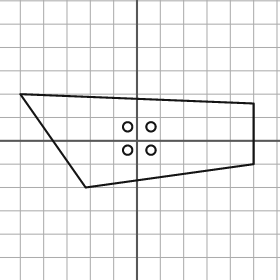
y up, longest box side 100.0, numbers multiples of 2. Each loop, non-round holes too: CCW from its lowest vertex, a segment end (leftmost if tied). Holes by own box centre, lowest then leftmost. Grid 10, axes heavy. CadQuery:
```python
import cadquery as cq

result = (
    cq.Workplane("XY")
    .moveTo(-22.0, -20.0)
    .lineTo(50.0, -10.0)
    .lineTo(50.0, 16.0)
    .lineTo(-50.0, 20.0)
    .close()
    .moveTo(-4.0, -4.0)
    .circle(2.0)
    .moveTo(6.0, -4.0)
    .circle(2.0)
    .moveTo(-4.0, 6.0)
    .circle(2.0)
    .moveTo(6.0, 6.0)
    .circle(2.0)
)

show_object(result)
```